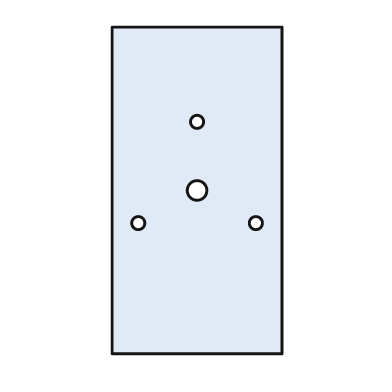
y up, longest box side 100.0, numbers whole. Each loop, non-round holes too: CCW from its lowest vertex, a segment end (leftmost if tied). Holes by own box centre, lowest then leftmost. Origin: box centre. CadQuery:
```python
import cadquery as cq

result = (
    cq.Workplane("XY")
    .moveTo(-26.0, -50.0)
    .lineTo(26.0, -50.0)
    .lineTo(26.0, 50.0)
    .lineTo(-26.0, 50.0)
    .close()
    .moveTo(-18.0, -10.0)
    .circle(2.0)
    .moveTo(18.0, -10.0)
    .circle(2.0)
    .moveTo(0.0, 0.0)
    .circle(3.0)
    .moveTo(0.0, 21.0)
    .circle(2.0)
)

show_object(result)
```